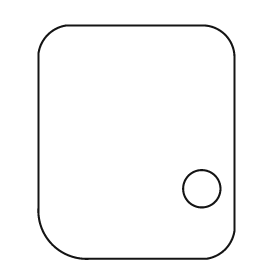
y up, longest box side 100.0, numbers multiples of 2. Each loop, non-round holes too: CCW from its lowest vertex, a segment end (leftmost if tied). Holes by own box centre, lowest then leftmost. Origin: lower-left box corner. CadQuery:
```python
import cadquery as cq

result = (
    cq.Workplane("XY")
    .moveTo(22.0, 0.0)
    .lineTo(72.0, 0.0)
    .threePointArc((80.0, 4.0), (84.0, 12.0))
    .lineTo(84.0, 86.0)
    .threePointArc((80.0, 96.0), (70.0, 100.0))
    .lineTo(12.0, 100.0)
    .threePointArc((4.0, 96.0), (0.0, 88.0))
    .lineTo(0.0, 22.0)
    .threePointArc((6.0, 6.0), (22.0, 0.0))
    .close()
    .moveTo(70.0, 30.0)
    .circle(8.0)
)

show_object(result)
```